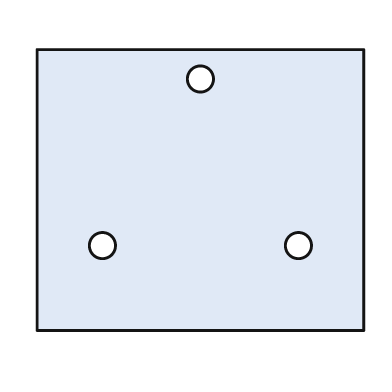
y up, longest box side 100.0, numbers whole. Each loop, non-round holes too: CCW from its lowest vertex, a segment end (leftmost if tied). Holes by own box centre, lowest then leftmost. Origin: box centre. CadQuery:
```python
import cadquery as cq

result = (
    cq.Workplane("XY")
    .moveTo(-50.0, -43.0)
    .lineTo(50.0, -43.0)
    .lineTo(50.0, 43.0)
    .lineTo(-50.0, 43.0)
    .close()
    .moveTo(-30.0, -17.0)
    .circle(4.0)
    .moveTo(30.0, -17.0)
    .circle(4.0)
    .moveTo(0.0, 34.0)
    .circle(4.0)
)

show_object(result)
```